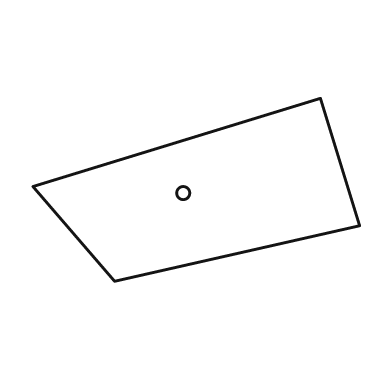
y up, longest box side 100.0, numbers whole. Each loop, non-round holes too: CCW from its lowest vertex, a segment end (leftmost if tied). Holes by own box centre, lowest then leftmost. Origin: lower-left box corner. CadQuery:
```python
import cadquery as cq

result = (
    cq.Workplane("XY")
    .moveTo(25.0, 0.0)
    .lineTo(100.0, 17.0)
    .lineTo(88.0, 56.0)
    .lineTo(0.0, 29.0)
    .close()
    .moveTo(46.0, 27.0)
    .circle(2.0)
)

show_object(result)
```